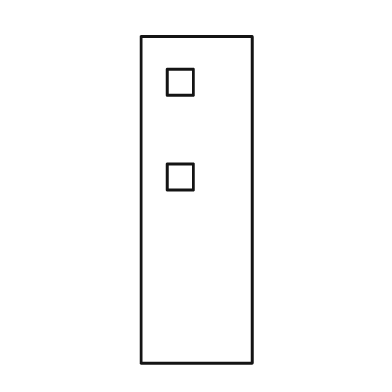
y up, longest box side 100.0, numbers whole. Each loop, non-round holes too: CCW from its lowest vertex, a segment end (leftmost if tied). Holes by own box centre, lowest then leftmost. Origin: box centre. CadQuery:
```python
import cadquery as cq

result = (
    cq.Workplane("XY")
    .moveTo(-17.0, -50.0)
    .lineTo(17.0, -50.0)
    .lineTo(17.0, 50.0)
    .lineTo(-17.0, 50.0)
    .close()
    .moveTo(-9.0, 3.0)
    .lineTo(-1.0, 3.0)
    .lineTo(-1.0, 11.0)
    .lineTo(-9.0, 11.0)
    .close()
    .moveTo(-9.0, 32.0)
    .lineTo(-1.0, 32.0)
    .lineTo(-1.0, 40.0)
    .lineTo(-9.0, 40.0)
    .close()
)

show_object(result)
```